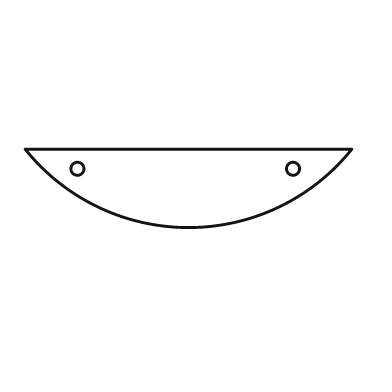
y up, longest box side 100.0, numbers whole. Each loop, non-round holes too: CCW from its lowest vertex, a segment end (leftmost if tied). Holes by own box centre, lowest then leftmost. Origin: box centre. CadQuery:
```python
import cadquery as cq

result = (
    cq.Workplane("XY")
    .moveTo(-50.0, 12.0)
    .threePointArc((0.0, -12.0), (50.0, 12.0))
    .close()
    .moveTo(-34.0, 6.0)
    .circle(2.0)
    .moveTo(32.0, 6.0)
    .circle(2.0)
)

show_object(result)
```